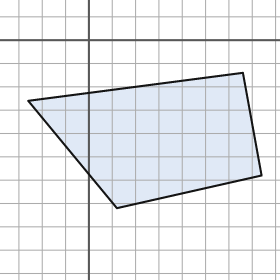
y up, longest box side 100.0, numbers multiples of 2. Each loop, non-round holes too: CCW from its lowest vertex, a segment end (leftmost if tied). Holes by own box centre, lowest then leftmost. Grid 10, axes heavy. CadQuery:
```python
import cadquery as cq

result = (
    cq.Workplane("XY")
    .moveTo(12.0, -72.0)
    .lineTo(74.0, -58.0)
    .lineTo(66.0, -14.0)
    .lineTo(-26.0, -26.0)
    .close()
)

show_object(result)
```